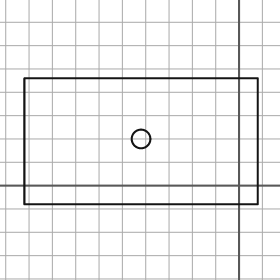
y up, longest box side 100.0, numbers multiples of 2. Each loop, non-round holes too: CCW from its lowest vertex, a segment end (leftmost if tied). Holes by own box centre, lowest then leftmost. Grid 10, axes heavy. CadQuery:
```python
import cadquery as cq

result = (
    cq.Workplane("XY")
    .moveTo(-92.0, -8.0)
    .lineTo(8.0, -8.0)
    .lineTo(8.0, 46.0)
    .lineTo(-92.0, 46.0)
    .close()
    .moveTo(-42.0, 20.0)
    .circle(4.0)
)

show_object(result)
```